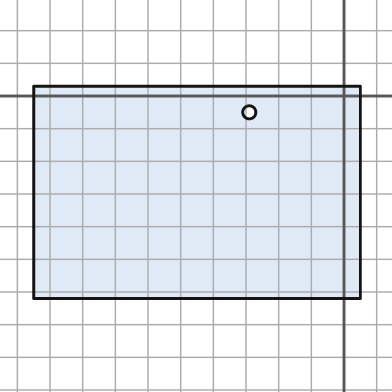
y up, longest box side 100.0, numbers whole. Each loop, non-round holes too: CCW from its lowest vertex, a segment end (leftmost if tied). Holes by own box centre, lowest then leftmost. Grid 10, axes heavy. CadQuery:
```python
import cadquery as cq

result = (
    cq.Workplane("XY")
    .moveTo(-95.0, -62.0)
    .lineTo(5.0, -62.0)
    .lineTo(5.0, 3.0)
    .lineTo(-95.0, 3.0)
    .close()
    .moveTo(-29.0, -5.0)
    .circle(2.0)
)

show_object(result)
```